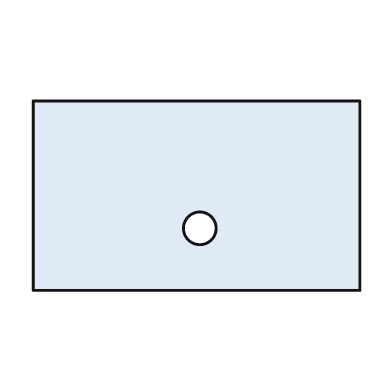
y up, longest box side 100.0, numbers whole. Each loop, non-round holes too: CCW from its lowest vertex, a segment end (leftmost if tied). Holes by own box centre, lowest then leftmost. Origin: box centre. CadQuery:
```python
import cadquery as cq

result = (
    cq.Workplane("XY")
    .moveTo(-50.0, -29.0)
    .lineTo(50.0, -29.0)
    .lineTo(50.0, 29.0)
    .lineTo(-50.0, 29.0)
    .close()
    .moveTo(1.0, -10.0)
    .circle(5.0)
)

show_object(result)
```